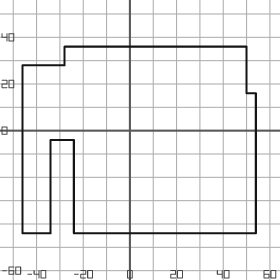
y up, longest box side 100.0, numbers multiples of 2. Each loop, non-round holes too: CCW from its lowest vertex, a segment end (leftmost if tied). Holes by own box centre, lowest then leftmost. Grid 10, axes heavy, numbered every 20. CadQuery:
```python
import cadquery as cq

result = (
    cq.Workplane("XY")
    .moveTo(-46.0, -44.0)
    .lineTo(-34.0, -44.0)
    .lineTo(-34.0, -4.0)
    .lineTo(-24.0, -4.0)
    .lineTo(-24.0, -44.0)
    .lineTo(54.0, -44.0)
    .lineTo(54.0, 16.0)
    .lineTo(50.0, 16.0)
    .lineTo(50.0, 36.0)
    .lineTo(-28.0, 36.0)
    .lineTo(-28.0, 28.0)
    .lineTo(-46.0, 28.0)
    .close()
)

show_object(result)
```